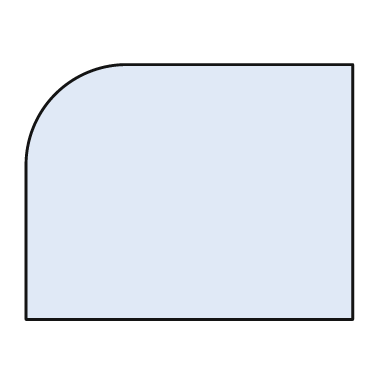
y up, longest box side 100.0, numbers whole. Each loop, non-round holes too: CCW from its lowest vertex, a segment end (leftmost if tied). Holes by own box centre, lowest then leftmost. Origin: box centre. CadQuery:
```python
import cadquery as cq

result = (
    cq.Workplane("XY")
    .moveTo(-50.0, -39.0)
    .lineTo(50.0, -39.0)
    .lineTo(50.0, 39.0)
    .lineTo(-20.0, 39.0)
    .threePointArc((-41.0, 30.0), (-50.0, 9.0))
    .close()
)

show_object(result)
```